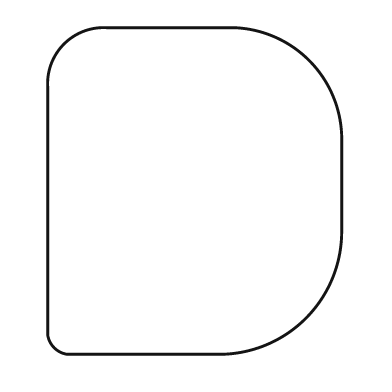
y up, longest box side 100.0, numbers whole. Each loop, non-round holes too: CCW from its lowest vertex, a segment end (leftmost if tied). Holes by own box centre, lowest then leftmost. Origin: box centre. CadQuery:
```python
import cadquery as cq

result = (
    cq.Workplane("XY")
    .moveTo(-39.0, -50.0)
    .lineTo(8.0, -50.0)
    .threePointArc((34.0, -39.0), (45.0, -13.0))
    .lineTo(45.0, 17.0)
    .threePointArc((35.0, 40.0), (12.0, 50.0))
    .lineTo(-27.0, 50.0)
    .threePointArc((-40.0, 45.0), (-45.0, 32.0))
    .lineTo(-45.0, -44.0)
    .threePointArc((-43.0, -48.0), (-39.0, -50.0))
    .close()
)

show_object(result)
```